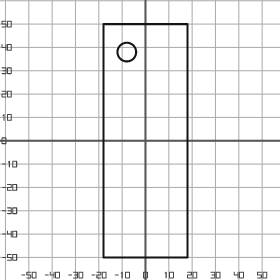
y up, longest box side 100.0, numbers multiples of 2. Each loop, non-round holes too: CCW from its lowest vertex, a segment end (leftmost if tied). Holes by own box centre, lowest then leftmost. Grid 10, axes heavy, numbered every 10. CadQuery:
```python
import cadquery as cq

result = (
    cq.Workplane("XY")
    .moveTo(-18.0, -50.0)
    .lineTo(18.0, -50.0)
    .lineTo(18.0, 50.0)
    .lineTo(-18.0, 50.0)
    .close()
    .moveTo(-8.0, 38.0)
    .circle(4.0)
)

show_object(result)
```